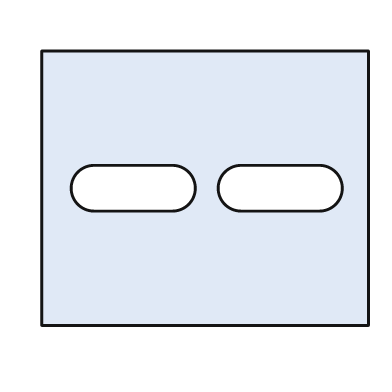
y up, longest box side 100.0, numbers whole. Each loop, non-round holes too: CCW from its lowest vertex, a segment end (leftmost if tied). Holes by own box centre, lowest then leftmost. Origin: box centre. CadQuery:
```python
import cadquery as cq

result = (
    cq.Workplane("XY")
    .moveTo(-50.0, -42.0)
    .lineTo(50.0, -42.0)
    .lineTo(50.0, 42.0)
    .lineTo(-50.0, 42.0)
    .close()
    .moveTo(-34.0, -7.0)
    .lineTo(-10.0, -7.0)
    .threePointArc((-3.0, 0.0), (-10.0, 7.0))
    .lineTo(-34.0, 7.0)
    .threePointArc((-41.0, 0.0), (-34.0, -7.0))
    .close()
    .moveTo(11.0, -7.0)
    .lineTo(35.0, -7.0)
    .threePointArc((42.0, 0.0), (35.0, 7.0))
    .lineTo(11.0, 7.0)
    .threePointArc((4.0, 0.0), (11.0, -7.0))
    .close()
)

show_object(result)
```